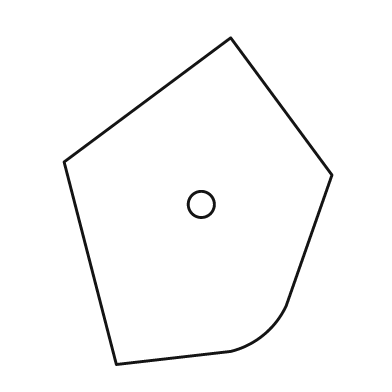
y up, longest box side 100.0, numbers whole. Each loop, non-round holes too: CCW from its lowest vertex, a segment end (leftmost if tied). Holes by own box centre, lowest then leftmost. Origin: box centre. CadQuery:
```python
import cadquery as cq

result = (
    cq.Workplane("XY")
    .moveTo(-25.0, -50.0)
    .lineTo(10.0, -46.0)
    .threePointArc((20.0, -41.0), (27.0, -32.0))
    .lineTo(41.0, 8.0)
    .lineTo(10.0, 50.0)
    .lineTo(-41.0, 12.0)
    .close()
    .moveTo(1.0, -1.0)
    .circle(4.0)
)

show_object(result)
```